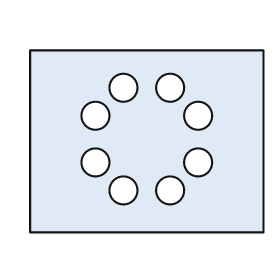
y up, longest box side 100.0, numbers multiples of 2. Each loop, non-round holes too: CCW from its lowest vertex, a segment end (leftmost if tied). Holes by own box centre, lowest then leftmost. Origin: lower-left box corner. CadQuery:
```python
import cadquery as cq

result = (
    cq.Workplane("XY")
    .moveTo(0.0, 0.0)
    .lineTo(100.0, 0.0)
    .lineTo(100.0, 78.0)
    .lineTo(0.0, 78.0)
    .close()
    .moveTo(40.0, 18.0)
    .circle(6.0)
    .moveTo(60.0, 18.0)
    .circle(6.0)
    .moveTo(28.0, 30.0)
    .circle(6.0)
    .moveTo(72.0, 30.0)
    .circle(6.0)
    .moveTo(28.0, 50.0)
    .circle(6.0)
    .moveTo(72.0, 50.0)
    .circle(6.0)
    .moveTo(40.0, 62.0)
    .circle(6.0)
    .moveTo(60.0, 62.0)
    .circle(6.0)
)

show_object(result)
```